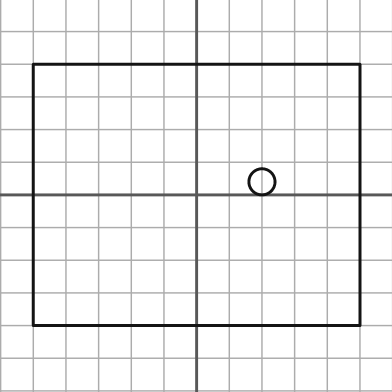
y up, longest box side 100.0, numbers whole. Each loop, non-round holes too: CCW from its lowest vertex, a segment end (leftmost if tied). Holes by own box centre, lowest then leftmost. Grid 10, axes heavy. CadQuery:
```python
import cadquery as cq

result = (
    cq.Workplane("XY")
    .moveTo(-50.0, -40.0)
    .lineTo(50.0, -40.0)
    .lineTo(50.0, 40.0)
    .lineTo(-50.0, 40.0)
    .close()
    .moveTo(20.0, 4.0)
    .circle(4.0)
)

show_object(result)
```